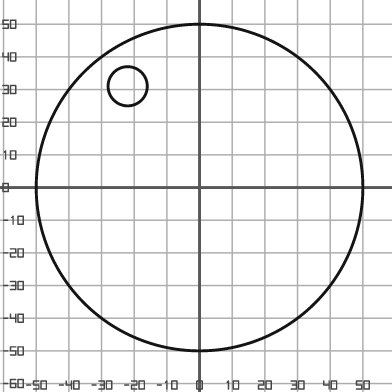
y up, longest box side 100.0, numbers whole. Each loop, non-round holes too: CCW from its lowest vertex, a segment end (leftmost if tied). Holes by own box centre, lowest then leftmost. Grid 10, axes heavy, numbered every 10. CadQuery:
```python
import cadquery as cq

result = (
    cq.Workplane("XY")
    .moveTo(0.0, 0.0)
    .circle(50.0)
    .moveTo(-22.0, 31.0)
    .circle(6.0)
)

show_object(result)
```